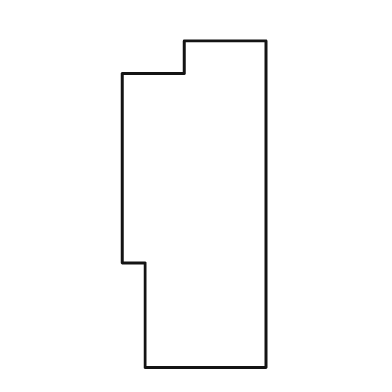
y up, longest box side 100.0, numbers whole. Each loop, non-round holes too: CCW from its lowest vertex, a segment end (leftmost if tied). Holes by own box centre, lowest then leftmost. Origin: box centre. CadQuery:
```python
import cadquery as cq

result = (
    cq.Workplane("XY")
    .moveTo(-15.0, -50.0)
    .lineTo(22.0, -50.0)
    .lineTo(22.0, 50.0)
    .lineTo(-3.0, 50.0)
    .lineTo(-3.0, 40.0)
    .lineTo(-22.0, 40.0)
    .lineTo(-22.0, -18.0)
    .lineTo(-15.0, -18.0)
    .close()
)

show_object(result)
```